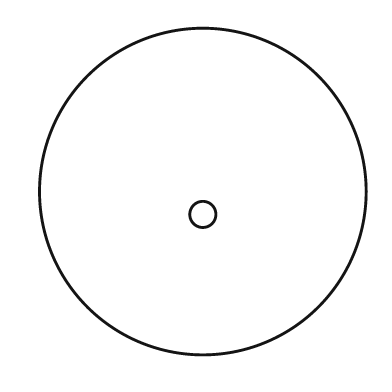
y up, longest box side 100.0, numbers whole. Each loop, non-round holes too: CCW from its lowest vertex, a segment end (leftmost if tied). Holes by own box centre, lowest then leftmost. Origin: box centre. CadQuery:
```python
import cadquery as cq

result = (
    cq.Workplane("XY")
    .moveTo(0.0, 0.0)
    .circle(50.0)
    .moveTo(0.0, -7.0)
    .circle(4.0)
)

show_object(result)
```